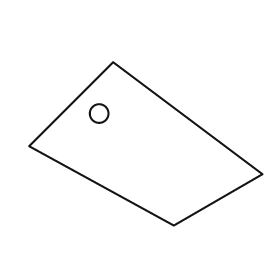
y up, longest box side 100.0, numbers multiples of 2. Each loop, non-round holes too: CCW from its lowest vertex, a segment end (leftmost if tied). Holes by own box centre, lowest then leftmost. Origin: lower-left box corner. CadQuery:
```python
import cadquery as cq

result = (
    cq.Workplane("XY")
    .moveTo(62.0, 0.0)
    .lineTo(100.0, 22.0)
    .lineTo(36.0, 70.0)
    .lineTo(0.0, 34.0)
    .close()
    .moveTo(30.0, 48.0)
    .circle(4.0)
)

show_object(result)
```